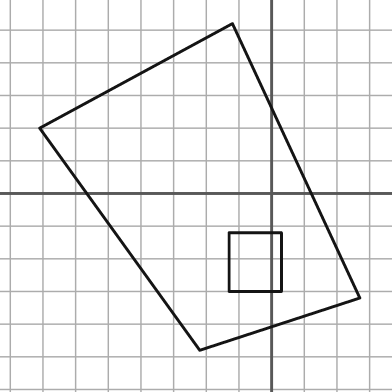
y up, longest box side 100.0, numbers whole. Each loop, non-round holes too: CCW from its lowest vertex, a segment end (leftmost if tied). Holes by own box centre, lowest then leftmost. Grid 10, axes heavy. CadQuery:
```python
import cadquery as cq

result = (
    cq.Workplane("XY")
    .moveTo(-22.0, -48.0)
    .lineTo(27.0, -32.0)
    .lineTo(-12.0, 52.0)
    .lineTo(-71.0, 20.0)
    .close()
    .moveTo(-13.0, -30.0)
    .lineTo(3.0, -30.0)
    .lineTo(3.0, -12.0)
    .lineTo(-13.0, -12.0)
    .close()
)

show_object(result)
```